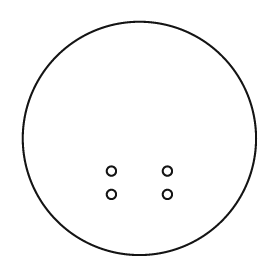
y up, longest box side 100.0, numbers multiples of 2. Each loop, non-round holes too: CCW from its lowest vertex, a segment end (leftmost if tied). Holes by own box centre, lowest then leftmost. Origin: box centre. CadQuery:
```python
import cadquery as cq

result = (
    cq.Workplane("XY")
    .moveTo(0.0, 0.0)
    .circle(50.0)
    .moveTo(-12.0, -24.0)
    .circle(2.0)
    .moveTo(12.0, -24.0)
    .circle(2.0)
    .moveTo(-12.0, -14.0)
    .circle(2.0)
    .moveTo(12.0, -14.0)
    .circle(2.0)
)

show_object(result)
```